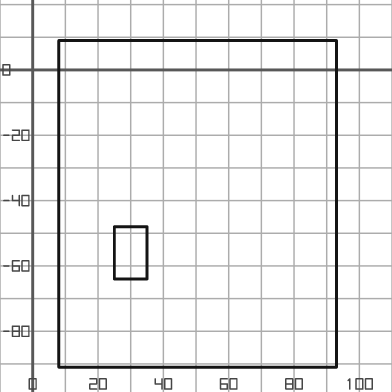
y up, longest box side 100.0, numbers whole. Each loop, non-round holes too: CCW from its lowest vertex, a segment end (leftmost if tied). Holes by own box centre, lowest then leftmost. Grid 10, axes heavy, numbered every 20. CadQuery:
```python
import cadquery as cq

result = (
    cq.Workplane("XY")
    .moveTo(8.0, -91.0)
    .lineTo(93.0, -91.0)
    .lineTo(93.0, 9.0)
    .lineTo(8.0, 9.0)
    .close()
    .moveTo(25.0, -64.0)
    .lineTo(35.0, -64.0)
    .lineTo(35.0, -48.0)
    .lineTo(25.0, -48.0)
    .close()
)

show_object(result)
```